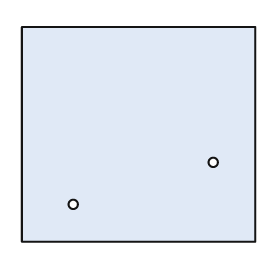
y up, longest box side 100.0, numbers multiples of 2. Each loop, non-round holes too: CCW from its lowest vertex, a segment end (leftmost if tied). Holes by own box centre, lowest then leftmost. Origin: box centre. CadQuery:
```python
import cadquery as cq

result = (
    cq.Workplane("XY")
    .moveTo(-50.0, -46.0)
    .lineTo(50.0, -46.0)
    .lineTo(50.0, 46.0)
    .lineTo(-50.0, 46.0)
    .close()
    .moveTo(-28.0, -30.0)
    .circle(2.0)
    .moveTo(32.0, -12.0)
    .circle(2.0)
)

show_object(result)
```